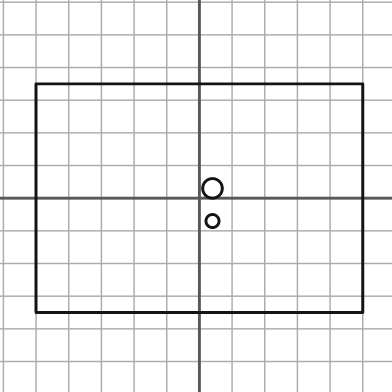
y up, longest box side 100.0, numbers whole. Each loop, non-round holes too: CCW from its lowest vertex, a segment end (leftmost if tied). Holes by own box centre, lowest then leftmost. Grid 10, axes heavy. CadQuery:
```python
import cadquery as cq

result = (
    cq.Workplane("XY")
    .moveTo(-50.0, -35.0)
    .lineTo(50.0, -35.0)
    .lineTo(50.0, 35.0)
    .lineTo(-50.0, 35.0)
    .close()
    .moveTo(4.0, -7.0)
    .circle(2.0)
    .moveTo(4.0, 3.0)
    .circle(3.0)
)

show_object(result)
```